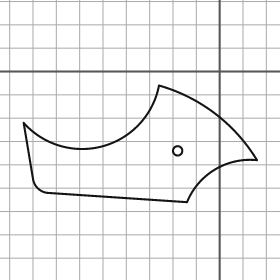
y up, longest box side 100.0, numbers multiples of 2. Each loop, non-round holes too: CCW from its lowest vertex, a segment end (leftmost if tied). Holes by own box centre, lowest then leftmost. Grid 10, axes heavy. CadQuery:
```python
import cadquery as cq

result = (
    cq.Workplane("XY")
    .moveTo(-14.0, -56.0)
    .threePointArc((-2.0, -42.0), (16.0, -38.0))
    .threePointArc((-2.0, -18.0), (-26.0, -6.0))
    .threePointArc((-50.0, -32.0), (-84.0, -22.0))
    .lineTo(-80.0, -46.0)
    .threePointArc((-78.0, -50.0), (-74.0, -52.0))
    .close()
    .moveTo(-18.0, -34.0)
    .circle(2.0)
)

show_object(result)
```